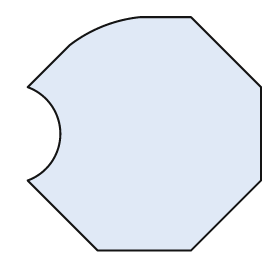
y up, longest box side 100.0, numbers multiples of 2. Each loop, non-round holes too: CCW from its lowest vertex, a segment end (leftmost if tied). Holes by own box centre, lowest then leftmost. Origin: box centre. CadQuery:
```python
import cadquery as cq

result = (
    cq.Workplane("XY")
    .moveTo(-20.0, -50.0)
    .lineTo(20.0, -50.0)
    .lineTo(50.0, -20.0)
    .lineTo(50.0, 20.0)
    .lineTo(20.0, 50.0)
    .lineTo(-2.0, 50.0)
    .threePointArc((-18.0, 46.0), (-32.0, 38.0))
    .lineTo(-50.0, 20.0)
    .threePointArc((-36.0, 0.0), (-50.0, -20.0))
    .close()
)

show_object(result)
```